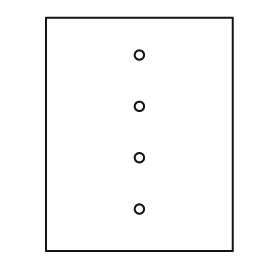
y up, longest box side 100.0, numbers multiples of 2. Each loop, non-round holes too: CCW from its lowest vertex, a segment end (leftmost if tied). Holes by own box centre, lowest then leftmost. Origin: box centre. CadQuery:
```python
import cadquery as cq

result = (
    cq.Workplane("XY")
    .moveTo(-40.0, -50.0)
    .lineTo(40.0, -50.0)
    .lineTo(40.0, 50.0)
    .lineTo(-40.0, 50.0)
    .close()
    .moveTo(0.0, -32.0)
    .circle(2.0)
    .moveTo(0.0, -10.0)
    .circle(2.0)
    .moveTo(0.0, 12.0)
    .circle(2.0)
    .moveTo(0.0, 34.0)
    .circle(2.0)
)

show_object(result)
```